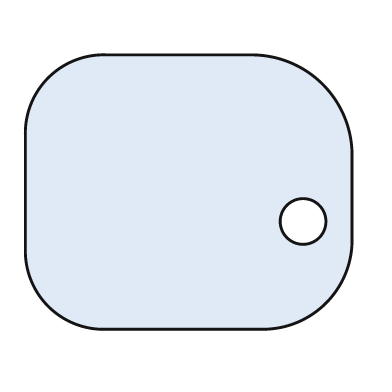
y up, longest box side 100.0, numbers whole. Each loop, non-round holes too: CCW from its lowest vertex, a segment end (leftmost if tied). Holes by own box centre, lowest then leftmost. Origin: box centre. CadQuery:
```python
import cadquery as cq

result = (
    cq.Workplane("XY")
    .moveTo(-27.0, -42.0)
    .lineTo(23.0, -42.0)
    .threePointArc((42.0, -34.0), (50.0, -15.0))
    .lineTo(50.0, 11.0)
    .threePointArc((41.0, 33.0), (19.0, 42.0))
    .lineTo(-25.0, 42.0)
    .threePointArc((-43.0, 35.0), (-50.0, 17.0))
    .lineTo(-50.0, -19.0)
    .threePointArc((-43.0, -35.0), (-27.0, -42.0))
    .close()
    .moveTo(35.0, -9.0)
    .circle(7.0)
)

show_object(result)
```